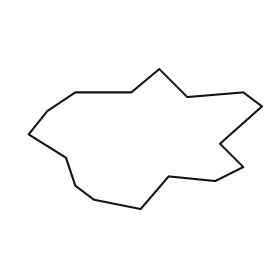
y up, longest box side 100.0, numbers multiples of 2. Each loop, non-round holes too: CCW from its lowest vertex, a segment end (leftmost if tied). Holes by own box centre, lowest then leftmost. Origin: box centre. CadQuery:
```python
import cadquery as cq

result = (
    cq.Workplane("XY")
    .moveTo(-2.0, -30.0)
    .lineTo(10.0, -16.0)
    .lineTo(30.0, -18.0)
    .lineTo(42.0, -12.0)
    .lineTo(32.0, -2.0)
    .lineTo(50.0, 14.0)
    .lineTo(42.0, 20.0)
    .lineTo(18.0, 18.0)
    .lineTo(6.0, 30.0)
    .lineTo(-6.0, 20.0)
    .lineTo(-30.0, 20.0)
    .lineTo(-42.0, 12.0)
    .lineTo(-50.0, 2.0)
    .lineTo(-34.0, -8.0)
    .lineTo(-30.0, -20.0)
    .lineTo(-22.0, -26.0)
    .close()
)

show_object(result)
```